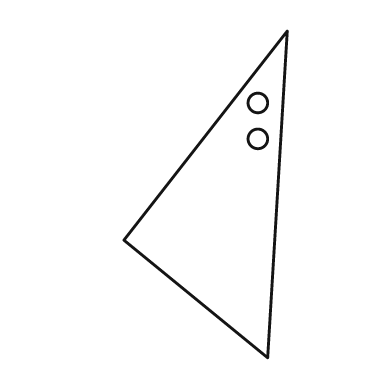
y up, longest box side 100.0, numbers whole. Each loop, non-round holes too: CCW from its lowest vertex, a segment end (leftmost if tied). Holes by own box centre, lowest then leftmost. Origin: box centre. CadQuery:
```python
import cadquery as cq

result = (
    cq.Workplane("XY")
    .moveTo(19.0, -50.0)
    .lineTo(25.0, 50.0)
    .lineTo(-25.0, -14.0)
    .close()
    .moveTo(16.0, 17.0)
    .circle(3.0)
    .moveTo(16.0, 28.0)
    .circle(3.0)
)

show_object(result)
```